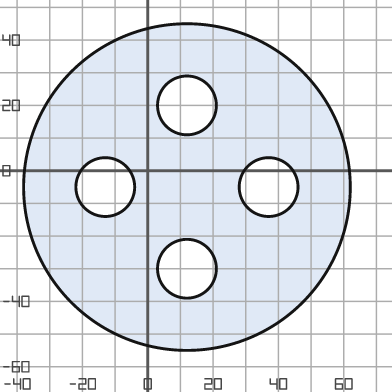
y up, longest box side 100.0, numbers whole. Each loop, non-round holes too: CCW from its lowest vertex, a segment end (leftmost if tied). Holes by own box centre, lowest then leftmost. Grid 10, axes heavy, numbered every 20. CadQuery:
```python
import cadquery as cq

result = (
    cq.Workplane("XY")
    .moveTo(12.0, -5.0)
    .circle(50.0)
    .moveTo(12.0, -30.0)
    .circle(9.0)
    .moveTo(-13.0, -5.0)
    .circle(9.0)
    .moveTo(37.0, -5.0)
    .circle(9.0)
    .moveTo(12.0, 20.0)
    .circle(9.0)
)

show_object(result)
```